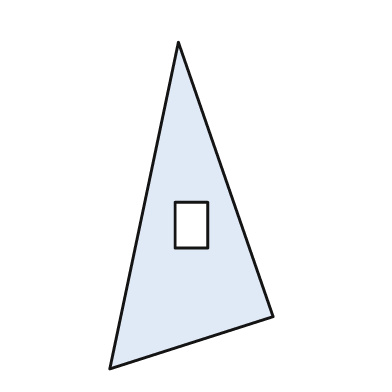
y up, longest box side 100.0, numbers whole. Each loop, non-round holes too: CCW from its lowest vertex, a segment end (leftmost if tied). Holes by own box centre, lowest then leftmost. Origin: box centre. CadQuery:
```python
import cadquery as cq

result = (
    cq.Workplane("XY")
    .moveTo(-25.0, -50.0)
    .lineTo(25.0, -34.0)
    .lineTo(-4.0, 50.0)
    .close()
    .moveTo(-5.0, -13.0)
    .lineTo(5.0, -13.0)
    .lineTo(5.0, 1.0)
    .lineTo(-5.0, 1.0)
    .close()
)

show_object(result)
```